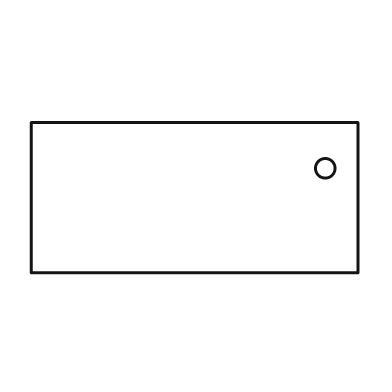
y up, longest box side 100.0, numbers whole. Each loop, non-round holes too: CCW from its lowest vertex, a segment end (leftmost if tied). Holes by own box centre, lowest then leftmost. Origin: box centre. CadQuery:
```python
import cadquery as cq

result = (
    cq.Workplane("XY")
    .moveTo(-50.0, -23.0)
    .lineTo(50.0, -23.0)
    .lineTo(50.0, 23.0)
    .lineTo(-50.0, 23.0)
    .close()
    .moveTo(40.0, 9.0)
    .circle(3.0)
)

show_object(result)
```